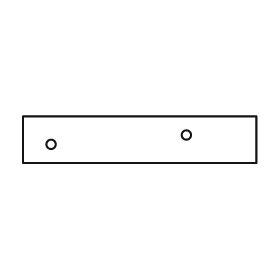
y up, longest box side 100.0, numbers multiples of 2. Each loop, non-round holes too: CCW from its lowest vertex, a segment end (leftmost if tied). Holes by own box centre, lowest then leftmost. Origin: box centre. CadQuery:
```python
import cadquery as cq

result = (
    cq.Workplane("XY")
    .moveTo(-50.0, -10.0)
    .lineTo(50.0, -10.0)
    .lineTo(50.0, 10.0)
    .lineTo(-50.0, 10.0)
    .close()
    .moveTo(-38.0, -2.0)
    .circle(2.0)
    .moveTo(20.0, 2.0)
    .circle(2.0)
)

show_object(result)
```